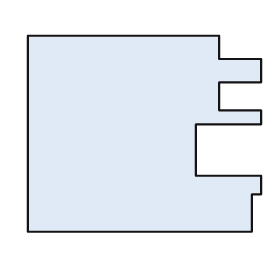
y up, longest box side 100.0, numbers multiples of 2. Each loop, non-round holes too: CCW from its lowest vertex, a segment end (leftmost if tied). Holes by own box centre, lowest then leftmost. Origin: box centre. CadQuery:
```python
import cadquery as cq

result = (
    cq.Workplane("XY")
    .moveTo(-50.0, -42.0)
    .lineTo(46.0, -42.0)
    .lineTo(46.0, -26.0)
    .lineTo(50.0, -26.0)
    .lineTo(50.0, -18.0)
    .lineTo(22.0, -18.0)
    .lineTo(22.0, 4.0)
    .lineTo(50.0, 4.0)
    .lineTo(50.0, 10.0)
    .lineTo(32.0, 10.0)
    .lineTo(32.0, 22.0)
    .lineTo(50.0, 22.0)
    .lineTo(50.0, 32.0)
    .lineTo(32.0, 32.0)
    .lineTo(32.0, 42.0)
    .lineTo(-50.0, 42.0)
    .close()
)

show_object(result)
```